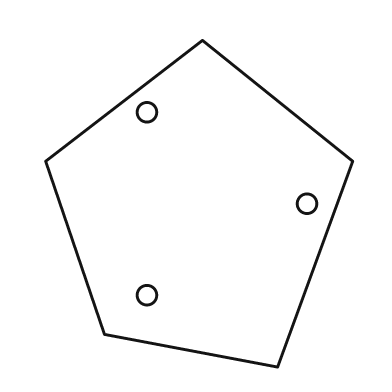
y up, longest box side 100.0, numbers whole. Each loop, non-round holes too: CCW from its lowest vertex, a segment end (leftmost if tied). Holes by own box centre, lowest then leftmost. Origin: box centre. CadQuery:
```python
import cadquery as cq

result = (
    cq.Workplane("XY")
    .moveTo(24.0, -50.0)
    .lineTo(47.0, 13.0)
    .lineTo(1.0, 50.0)
    .lineTo(-47.0, 13.0)
    .lineTo(-29.0, -40.0)
    .close()
    .moveTo(-16.0, -28.0)
    .circle(3.0)
    .moveTo(33.0, 0.0)
    .circle(3.0)
    .moveTo(-16.0, 28.0)
    .circle(3.0)
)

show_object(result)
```